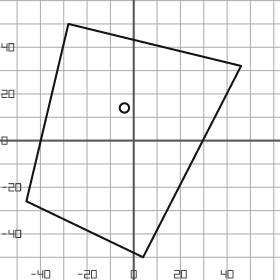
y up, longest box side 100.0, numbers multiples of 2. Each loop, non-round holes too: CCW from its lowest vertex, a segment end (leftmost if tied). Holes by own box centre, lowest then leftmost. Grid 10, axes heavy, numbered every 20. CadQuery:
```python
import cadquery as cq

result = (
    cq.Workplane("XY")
    .moveTo(4.0, -50.0)
    .lineTo(46.0, 32.0)
    .lineTo(-28.0, 50.0)
    .lineTo(-46.0, -26.0)
    .close()
    .moveTo(-4.0, 14.0)
    .circle(2.0)
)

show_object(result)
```